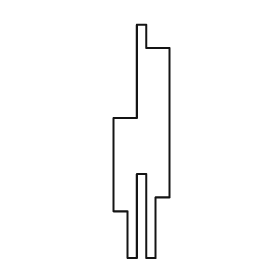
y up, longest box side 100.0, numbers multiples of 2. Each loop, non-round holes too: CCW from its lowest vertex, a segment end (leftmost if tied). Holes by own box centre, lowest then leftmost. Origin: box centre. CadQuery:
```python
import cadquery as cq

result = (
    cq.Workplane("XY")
    .moveTo(-6.0, -50.0)
    .lineTo(-2.0, -50.0)
    .lineTo(-2.0, -14.0)
    .lineTo(2.0, -14.0)
    .lineTo(2.0, -50.0)
    .lineTo(6.0, -50.0)
    .lineTo(6.0, -24.0)
    .lineTo(12.0, -24.0)
    .lineTo(12.0, 40.0)
    .lineTo(2.0, 40.0)
    .lineTo(2.0, 50.0)
    .lineTo(-2.0, 50.0)
    .lineTo(-2.0, 10.0)
    .lineTo(-12.0, 10.0)
    .lineTo(-12.0, -30.0)
    .lineTo(-6.0, -30.0)
    .close()
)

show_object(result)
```